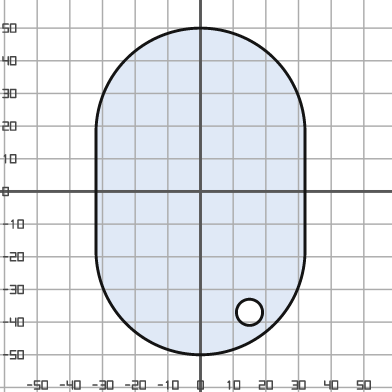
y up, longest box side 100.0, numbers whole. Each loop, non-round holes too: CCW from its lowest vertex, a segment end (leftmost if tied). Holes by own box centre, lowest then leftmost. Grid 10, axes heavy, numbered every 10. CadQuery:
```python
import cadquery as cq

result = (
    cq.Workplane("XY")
    .moveTo(-32.0, -18.0)
    .threePointArc((0.0, -50.0), (32.0, -18.0))
    .lineTo(32.0, 18.0)
    .threePointArc((0.0, 50.0), (-32.0, 18.0))
    .close()
    .moveTo(15.0, -37.0)
    .circle(4.0)
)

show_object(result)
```